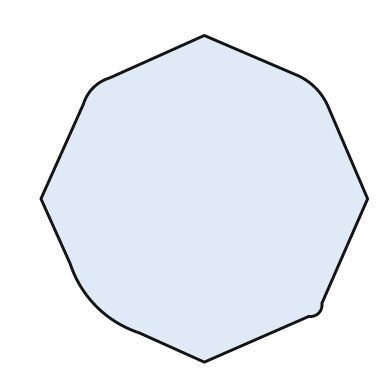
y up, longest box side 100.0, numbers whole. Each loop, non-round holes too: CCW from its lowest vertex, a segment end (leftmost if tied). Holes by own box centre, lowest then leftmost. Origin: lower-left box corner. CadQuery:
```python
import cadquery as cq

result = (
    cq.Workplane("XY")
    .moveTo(50.0, 0.0)
    .lineTo(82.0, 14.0)
    .threePointArc((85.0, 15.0), (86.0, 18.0))
    .lineTo(100.0, 50.0)
    .lineTo(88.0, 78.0)
    .threePointArc((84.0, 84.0), (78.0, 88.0))
    .lineTo(50.0, 100.0)
    .lineTo(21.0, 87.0)
    .threePointArc((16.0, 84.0), (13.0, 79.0))
    .lineTo(0.0, 50.0)
    .lineTo(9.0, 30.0)
    .threePointArc((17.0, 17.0), (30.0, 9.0))
    .close()
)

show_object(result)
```